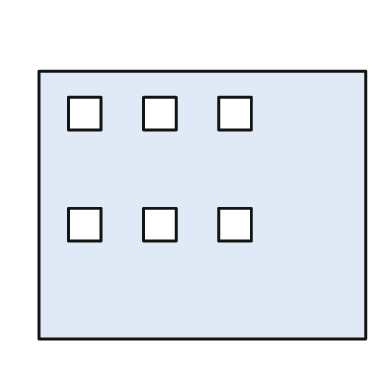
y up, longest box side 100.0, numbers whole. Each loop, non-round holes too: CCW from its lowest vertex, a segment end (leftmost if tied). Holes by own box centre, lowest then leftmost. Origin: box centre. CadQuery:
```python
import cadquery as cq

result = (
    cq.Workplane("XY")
    .moveTo(-50.0, -41.0)
    .lineTo(50.0, -41.0)
    .lineTo(50.0, 41.0)
    .lineTo(-50.0, 41.0)
    .close()
    .moveTo(-41.0, -11.0)
    .lineTo(-31.0, -11.0)
    .lineTo(-31.0, -1.0)
    .lineTo(-41.0, -1.0)
    .close()
    .moveTo(-18.0, -11.0)
    .lineTo(-8.0, -11.0)
    .lineTo(-8.0, -1.0)
    .lineTo(-18.0, -1.0)
    .close()
    .moveTo(5.0, -11.0)
    .lineTo(15.0, -11.0)
    .lineTo(15.0, -1.0)
    .lineTo(5.0, -1.0)
    .close()
    .moveTo(-41.0, 23.0)
    .lineTo(-31.0, 23.0)
    .lineTo(-31.0, 33.0)
    .lineTo(-41.0, 33.0)
    .close()
    .moveTo(-18.0, 23.0)
    .lineTo(-8.0, 23.0)
    .lineTo(-8.0, 33.0)
    .lineTo(-18.0, 33.0)
    .close()
    .moveTo(5.0, 23.0)
    .lineTo(15.0, 23.0)
    .lineTo(15.0, 33.0)
    .lineTo(5.0, 33.0)
    .close()
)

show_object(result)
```